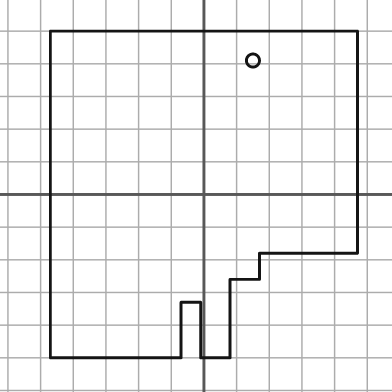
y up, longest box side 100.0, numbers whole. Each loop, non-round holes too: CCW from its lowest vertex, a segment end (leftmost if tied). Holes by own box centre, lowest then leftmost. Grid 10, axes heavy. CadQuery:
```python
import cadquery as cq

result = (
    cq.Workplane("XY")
    .moveTo(-47.0, -50.0)
    .lineTo(-7.0, -50.0)
    .lineTo(-7.0, -33.0)
    .lineTo(-1.0, -33.0)
    .lineTo(-1.0, -50.0)
    .lineTo(8.0, -50.0)
    .lineTo(8.0, -26.0)
    .lineTo(17.0, -26.0)
    .lineTo(17.0, -18.0)
    .lineTo(47.0, -18.0)
    .lineTo(47.0, 50.0)
    .lineTo(-47.0, 50.0)
    .close()
    .moveTo(15.0, 41.0)
    .circle(2.0)
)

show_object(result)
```